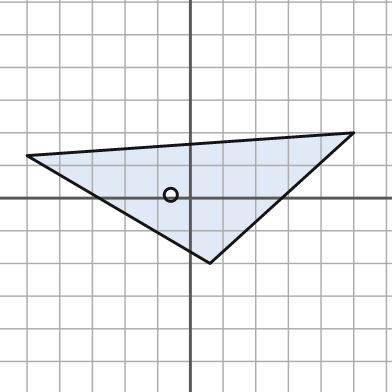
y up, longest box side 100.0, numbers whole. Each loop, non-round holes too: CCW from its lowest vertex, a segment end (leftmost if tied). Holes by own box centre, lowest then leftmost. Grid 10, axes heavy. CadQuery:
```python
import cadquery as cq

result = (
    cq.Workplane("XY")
    .moveTo(6.0, -20.0)
    .lineTo(50.0, 20.0)
    .lineTo(-50.0, 13.0)
    .close()
    .moveTo(-6.0, 1.0)
    .circle(2.0)
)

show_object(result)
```